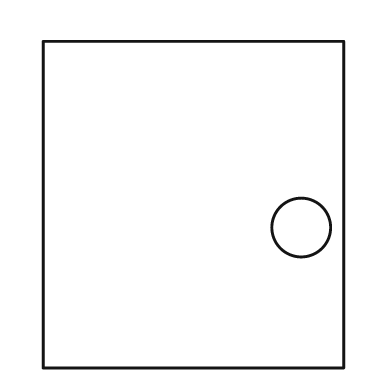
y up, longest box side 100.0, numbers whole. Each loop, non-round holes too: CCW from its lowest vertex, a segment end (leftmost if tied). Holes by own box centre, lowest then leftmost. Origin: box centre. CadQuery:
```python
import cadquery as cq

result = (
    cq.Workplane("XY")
    .moveTo(-46.0, -50.0)
    .lineTo(46.0, -50.0)
    .lineTo(46.0, 50.0)
    .lineTo(-46.0, 50.0)
    .close()
    .moveTo(33.0, -7.0)
    .circle(9.0)
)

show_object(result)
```